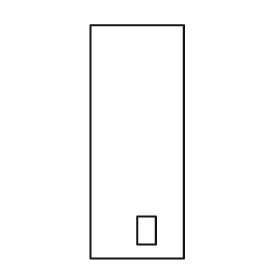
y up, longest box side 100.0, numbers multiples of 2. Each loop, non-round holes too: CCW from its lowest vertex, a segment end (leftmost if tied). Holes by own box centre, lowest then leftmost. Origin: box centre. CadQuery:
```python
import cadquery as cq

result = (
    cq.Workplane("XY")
    .moveTo(-20.0, -50.0)
    .lineTo(20.0, -50.0)
    .lineTo(20.0, 50.0)
    .lineTo(-20.0, 50.0)
    .close()
    .moveTo(0.0, -44.0)
    .lineTo(8.0, -44.0)
    .lineTo(8.0, -32.0)
    .lineTo(0.0, -32.0)
    .close()
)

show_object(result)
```